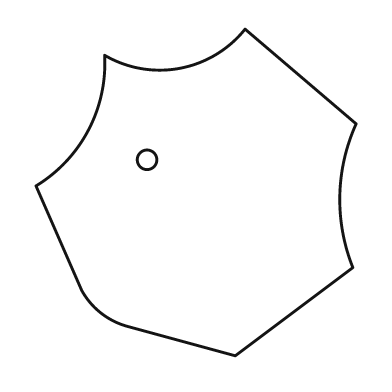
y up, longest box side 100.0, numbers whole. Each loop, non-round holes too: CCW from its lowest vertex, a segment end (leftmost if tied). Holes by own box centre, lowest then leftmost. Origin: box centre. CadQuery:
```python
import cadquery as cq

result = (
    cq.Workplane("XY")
    .moveTo(12.0, -50.0)
    .lineTo(48.0, -23.0)
    .threePointArc((44.0, -1.0), (49.0, 21.0))
    .lineTo(15.0, 50.0)
    .threePointArc((-5.0, 38.0), (-28.0, 42.0))
    .threePointArc((-33.0, 19.0), (-49.0, 2.0))
    .lineTo(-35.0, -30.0)
    .threePointArc((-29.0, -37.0), (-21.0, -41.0))
    .close()
    .moveTo(-15.0, 10.0)
    .circle(3.0)
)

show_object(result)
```